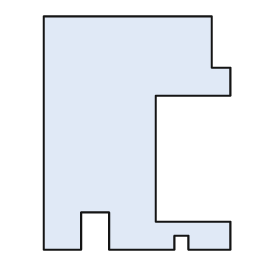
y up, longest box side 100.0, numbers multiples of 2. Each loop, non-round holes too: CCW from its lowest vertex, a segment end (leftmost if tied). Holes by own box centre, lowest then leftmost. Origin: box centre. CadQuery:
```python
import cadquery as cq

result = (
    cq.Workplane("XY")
    .moveTo(-40.0, -50.0)
    .lineTo(-24.0, -50.0)
    .lineTo(-24.0, -34.0)
    .lineTo(-12.0, -34.0)
    .lineTo(-12.0, -50.0)
    .lineTo(16.0, -50.0)
    .lineTo(16.0, -44.0)
    .lineTo(22.0, -44.0)
    .lineTo(22.0, -50.0)
    .lineTo(40.0, -50.0)
    .lineTo(40.0, -38.0)
    .lineTo(8.0, -38.0)
    .lineTo(8.0, 16.0)
    .lineTo(40.0, 16.0)
    .lineTo(40.0, 28.0)
    .lineTo(32.0, 28.0)
    .lineTo(32.0, 50.0)
    .lineTo(-40.0, 50.0)
    .close()
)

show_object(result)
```